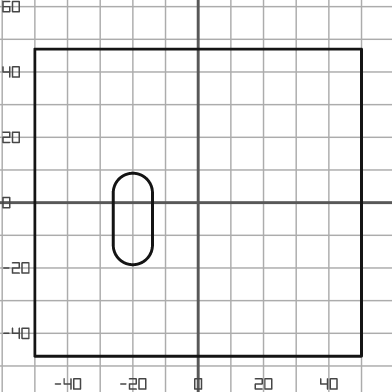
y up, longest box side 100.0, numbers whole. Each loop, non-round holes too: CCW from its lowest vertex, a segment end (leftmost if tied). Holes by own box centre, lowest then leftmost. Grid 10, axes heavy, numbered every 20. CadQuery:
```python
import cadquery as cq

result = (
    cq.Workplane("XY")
    .moveTo(-50.0, -47.0)
    .lineTo(50.0, -47.0)
    .lineTo(50.0, 47.0)
    .lineTo(-50.0, 47.0)
    .close()
    .moveTo(-26.0, -13.0)
    .threePointArc((-20.0, -19.0), (-14.0, -13.0))
    .lineTo(-14.0, 3.0)
    .threePointArc((-20.0, 9.0), (-26.0, 3.0))
    .close()
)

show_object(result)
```